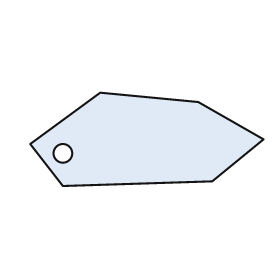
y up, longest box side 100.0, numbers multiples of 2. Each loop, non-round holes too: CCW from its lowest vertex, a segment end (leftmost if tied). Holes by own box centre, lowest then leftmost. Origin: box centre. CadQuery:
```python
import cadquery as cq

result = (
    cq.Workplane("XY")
    .moveTo(-36.0, -20.0)
    .lineTo(28.0, -18.0)
    .lineTo(50.0, 0.0)
    .lineTo(22.0, 16.0)
    .lineTo(-20.0, 20.0)
    .lineTo(-50.0, -2.0)
    .close()
    .moveTo(-36.0, -6.0)
    .circle(4.0)
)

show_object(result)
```